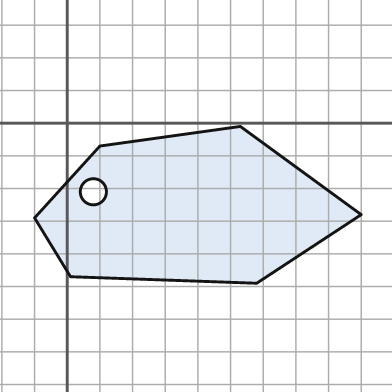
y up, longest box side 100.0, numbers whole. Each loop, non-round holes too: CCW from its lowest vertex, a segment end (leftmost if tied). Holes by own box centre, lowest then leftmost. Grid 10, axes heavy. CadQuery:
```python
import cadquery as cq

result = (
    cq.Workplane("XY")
    .moveTo(58.0, -49.0)
    .lineTo(90.0, -28.0)
    .lineTo(53.0, -1.0)
    .lineTo(10.0, -7.0)
    .lineTo(-10.0, -29.0)
    .lineTo(1.0, -47.0)
    .close()
    .moveTo(8.0, -21.0)
    .circle(4.0)
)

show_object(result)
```